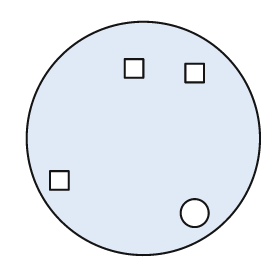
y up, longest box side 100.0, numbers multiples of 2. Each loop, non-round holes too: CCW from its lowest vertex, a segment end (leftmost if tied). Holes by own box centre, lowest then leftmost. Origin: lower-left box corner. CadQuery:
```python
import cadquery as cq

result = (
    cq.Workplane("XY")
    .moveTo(50.0, 50.0)
    .circle(50.0)
    .moveTo(72.0, 18.0)
    .circle(6.0)
    .moveTo(10.0, 28.0)
    .lineTo(18.0, 28.0)
    .lineTo(18.0, 36.0)
    .lineTo(10.0, 36.0)
    .close()
    .moveTo(68.0, 74.0)
    .lineTo(76.0, 74.0)
    .lineTo(76.0, 82.0)
    .lineTo(68.0, 82.0)
    .close()
    .moveTo(42.0, 76.0)
    .lineTo(50.0, 76.0)
    .lineTo(50.0, 84.0)
    .lineTo(42.0, 84.0)
    .close()
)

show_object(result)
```